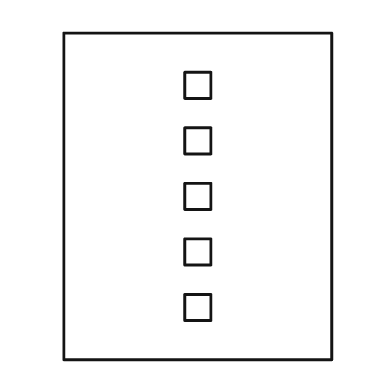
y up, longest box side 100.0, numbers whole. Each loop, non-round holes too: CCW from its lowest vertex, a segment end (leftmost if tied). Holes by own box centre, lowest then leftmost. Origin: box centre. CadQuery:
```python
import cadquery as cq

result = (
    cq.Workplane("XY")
    .moveTo(-41.0, -50.0)
    .lineTo(41.0, -50.0)
    .lineTo(41.0, 50.0)
    .lineTo(-41.0, 50.0)
    .close()
    .moveTo(-4.0, -38.0)
    .lineTo(4.0, -38.0)
    .lineTo(4.0, -30.0)
    .lineTo(-4.0, -30.0)
    .close()
    .moveTo(-4.0, -21.0)
    .lineTo(4.0, -21.0)
    .lineTo(4.0, -13.0)
    .lineTo(-4.0, -13.0)
    .close()
    .moveTo(-4.0, -4.0)
    .lineTo(4.0, -4.0)
    .lineTo(4.0, 4.0)
    .lineTo(-4.0, 4.0)
    .close()
    .moveTo(-4.0, 13.0)
    .lineTo(4.0, 13.0)
    .lineTo(4.0, 21.0)
    .lineTo(-4.0, 21.0)
    .close()
    .moveTo(-4.0, 30.0)
    .lineTo(4.0, 30.0)
    .lineTo(4.0, 38.0)
    .lineTo(-4.0, 38.0)
    .close()
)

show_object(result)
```